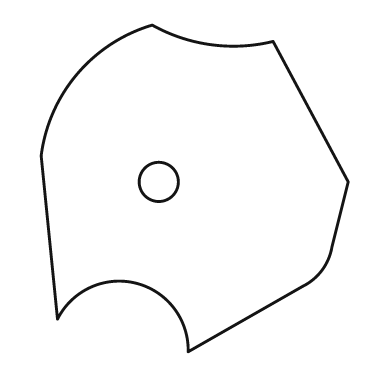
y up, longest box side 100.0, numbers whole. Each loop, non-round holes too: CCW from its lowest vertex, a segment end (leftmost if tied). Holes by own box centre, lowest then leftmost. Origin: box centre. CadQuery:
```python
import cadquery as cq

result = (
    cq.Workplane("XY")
    .moveTo(-2.0, -50.0)
    .lineTo(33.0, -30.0)
    .threePointArc((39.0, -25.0), (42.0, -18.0))
    .lineTo(47.0, 2.0)
    .lineTo(24.0, 45.0)
    .threePointArc((5.0, 44.0), (-13.0, 50.0))
    .threePointArc((-36.0, 35.0), (-47.0, 10.0))
    .lineTo(-42.0, -40.0)
    .threePointArc((-18.0, -29.0), (-2.0, -50.0))
    .close()
    .moveTo(-11.0, 2.0)
    .circle(6.0)
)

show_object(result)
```